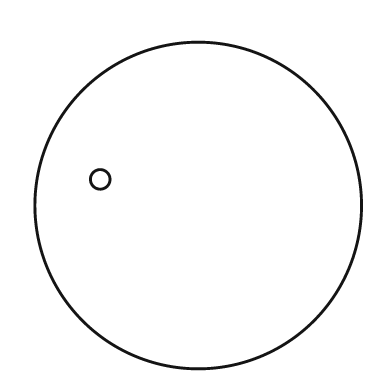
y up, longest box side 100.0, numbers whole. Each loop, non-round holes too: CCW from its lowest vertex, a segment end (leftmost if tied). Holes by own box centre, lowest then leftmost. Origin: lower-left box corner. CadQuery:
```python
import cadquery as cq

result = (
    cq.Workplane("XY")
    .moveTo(50.0, 50.0)
    .circle(50.0)
    .moveTo(20.0, 58.0)
    .circle(3.0)
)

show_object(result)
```